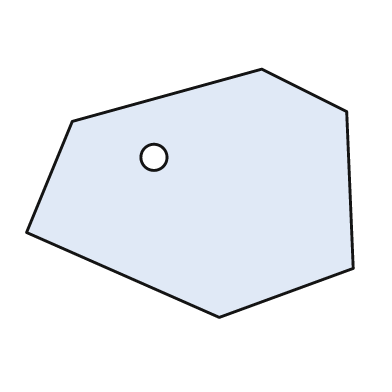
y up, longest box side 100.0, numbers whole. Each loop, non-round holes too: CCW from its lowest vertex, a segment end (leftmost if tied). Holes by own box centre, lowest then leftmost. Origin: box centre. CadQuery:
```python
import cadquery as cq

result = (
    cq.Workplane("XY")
    .moveTo(9.0, -38.0)
    .lineTo(50.0, -23.0)
    .lineTo(48.0, 25.0)
    .lineTo(22.0, 38.0)
    .lineTo(-36.0, 22.0)
    .lineTo(-50.0, -12.0)
    .close()
    .moveTo(-11.0, 11.0)
    .circle(4.0)
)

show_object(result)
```